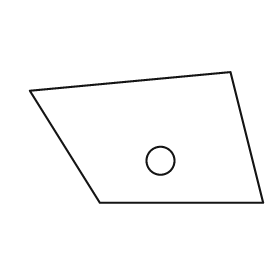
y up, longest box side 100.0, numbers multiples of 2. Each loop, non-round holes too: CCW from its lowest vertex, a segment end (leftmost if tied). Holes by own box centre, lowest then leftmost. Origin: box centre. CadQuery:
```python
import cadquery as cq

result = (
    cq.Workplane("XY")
    .moveTo(-20.0, -28.0)
    .lineTo(50.0, -28.0)
    .lineTo(36.0, 28.0)
    .lineTo(-50.0, 20.0)
    .close()
    .moveTo(6.0, -10.0)
    .circle(6.0)
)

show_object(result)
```